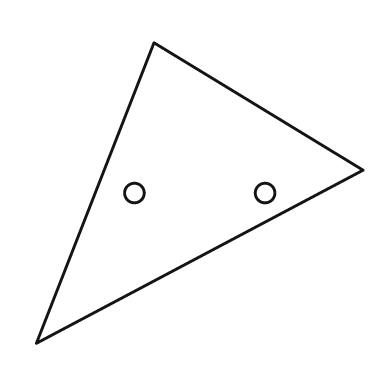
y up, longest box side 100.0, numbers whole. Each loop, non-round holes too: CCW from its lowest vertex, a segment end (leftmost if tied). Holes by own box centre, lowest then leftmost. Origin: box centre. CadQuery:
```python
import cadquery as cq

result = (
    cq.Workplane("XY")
    .moveTo(-50.0, -46.0)
    .lineTo(50.0, 7.0)
    .lineTo(-14.0, 46.0)
    .close()
    .moveTo(-20.0, 0.0)
    .circle(3.0)
    .moveTo(20.0, 0.0)
    .circle(3.0)
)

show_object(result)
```